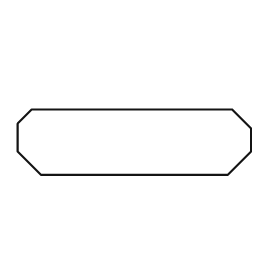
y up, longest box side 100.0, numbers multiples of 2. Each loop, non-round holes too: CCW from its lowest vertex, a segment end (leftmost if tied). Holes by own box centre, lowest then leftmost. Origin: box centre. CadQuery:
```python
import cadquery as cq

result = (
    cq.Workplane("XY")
    .moveTo(-40.0, -14.0)
    .lineTo(40.0, -14.0)
    .lineTo(50.0, -4.0)
    .lineTo(50.0, 6.0)
    .lineTo(42.0, 14.0)
    .lineTo(-44.0, 14.0)
    .lineTo(-50.0, 8.0)
    .lineTo(-50.0, -4.0)
    .close()
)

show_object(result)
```